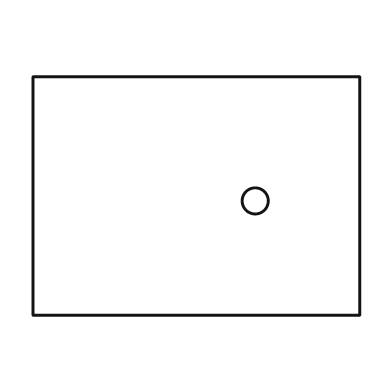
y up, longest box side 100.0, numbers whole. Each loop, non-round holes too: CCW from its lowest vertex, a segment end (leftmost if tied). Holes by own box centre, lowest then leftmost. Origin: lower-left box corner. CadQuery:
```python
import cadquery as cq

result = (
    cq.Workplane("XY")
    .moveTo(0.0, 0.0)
    .lineTo(100.0, 0.0)
    .lineTo(100.0, 73.0)
    .lineTo(0.0, 73.0)
    .close()
    .moveTo(68.0, 35.0)
    .circle(4.0)
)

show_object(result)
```